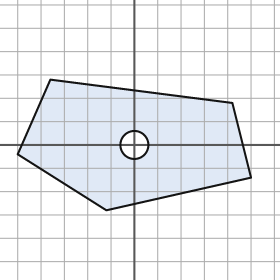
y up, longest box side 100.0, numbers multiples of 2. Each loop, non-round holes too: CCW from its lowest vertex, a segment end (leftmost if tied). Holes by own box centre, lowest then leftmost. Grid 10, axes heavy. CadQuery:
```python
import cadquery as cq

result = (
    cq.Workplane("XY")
    .moveTo(-12.0, -28.0)
    .lineTo(50.0, -14.0)
    .lineTo(42.0, 18.0)
    .lineTo(-36.0, 28.0)
    .lineTo(-50.0, -4.0)
    .close()
    .moveTo(0.0, 0.0)
    .circle(6.0)
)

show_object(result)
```